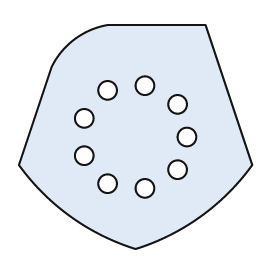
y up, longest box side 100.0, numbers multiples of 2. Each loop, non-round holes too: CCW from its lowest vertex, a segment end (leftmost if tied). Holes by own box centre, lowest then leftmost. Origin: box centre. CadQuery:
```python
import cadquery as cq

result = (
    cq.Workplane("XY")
    .moveTo(0.0, -48.0)
    .threePointArc((28.0, -34.0), (50.0, -12.0))
    .lineTo(30.0, 48.0)
    .lineTo(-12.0, 48.0)
    .threePointArc((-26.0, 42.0), (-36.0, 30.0))
    .lineTo(-50.0, -12.0)
    .threePointArc((-28.0, -34.0), (0.0, -48.0))
    .close()
    .moveTo(4.0, -22.0)
    .circle(4.0)
    .moveTo(-12.0, -20.0)
    .circle(4.0)
    .moveTo(18.0, -14.0)
    .circle(4.0)
    .moveTo(-22.0, -8.0)
    .circle(4.0)
    .moveTo(22.0, 0.0)
    .circle(4.0)
    .moveTo(-22.0, 8.0)
    .circle(4.0)
    .moveTo(18.0, 14.0)
    .circle(4.0)
    .moveTo(-12.0, 20.0)
    .circle(4.0)
    .moveTo(4.0, 22.0)
    .circle(4.0)
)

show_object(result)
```